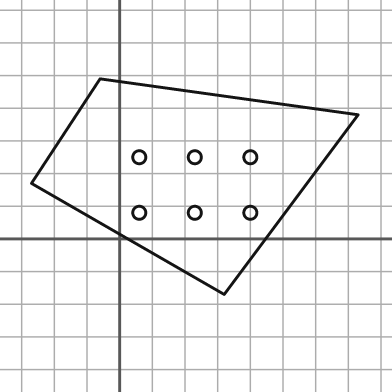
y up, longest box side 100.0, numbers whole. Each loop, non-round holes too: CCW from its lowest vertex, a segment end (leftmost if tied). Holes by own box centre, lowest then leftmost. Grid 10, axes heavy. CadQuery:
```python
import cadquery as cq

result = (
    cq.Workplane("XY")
    .moveTo(32.0, -17.0)
    .lineTo(73.0, 38.0)
    .lineTo(-6.0, 49.0)
    .lineTo(-27.0, 17.0)
    .close()
    .moveTo(6.0, 8.0)
    .circle(2.0)
    .moveTo(23.0, 8.0)
    .circle(2.0)
    .moveTo(40.0, 8.0)
    .circle(2.0)
    .moveTo(6.0, 25.0)
    .circle(2.0)
    .moveTo(23.0, 25.0)
    .circle(2.0)
    .moveTo(40.0, 25.0)
    .circle(2.0)
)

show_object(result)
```